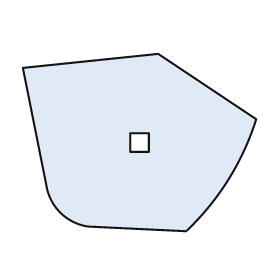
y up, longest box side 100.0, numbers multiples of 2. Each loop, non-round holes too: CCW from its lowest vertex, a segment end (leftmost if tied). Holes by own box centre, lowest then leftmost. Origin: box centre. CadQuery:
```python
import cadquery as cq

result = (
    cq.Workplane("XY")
    .moveTo(20.0, -38.0)
    .threePointArc((38.0, -16.0), (50.0, 10.0))
    .lineTo(8.0, 38.0)
    .lineTo(-50.0, 32.0)
    .lineTo(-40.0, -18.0)
    .threePointArc((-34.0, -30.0), (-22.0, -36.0))
    .close()
    .moveTo(-4.0, -4.0)
    .lineTo(4.0, -4.0)
    .lineTo(4.0, 4.0)
    .lineTo(-4.0, 4.0)
    .close()
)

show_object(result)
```